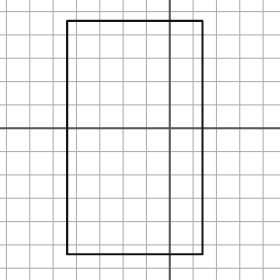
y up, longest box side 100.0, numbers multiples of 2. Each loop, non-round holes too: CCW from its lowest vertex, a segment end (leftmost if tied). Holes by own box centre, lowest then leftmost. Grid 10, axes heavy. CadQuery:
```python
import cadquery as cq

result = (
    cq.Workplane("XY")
    .moveTo(-44.0, -54.0)
    .lineTo(14.0, -54.0)
    .lineTo(14.0, 46.0)
    .lineTo(-44.0, 46.0)
    .close()
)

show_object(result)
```